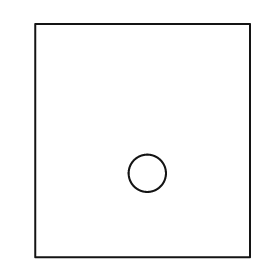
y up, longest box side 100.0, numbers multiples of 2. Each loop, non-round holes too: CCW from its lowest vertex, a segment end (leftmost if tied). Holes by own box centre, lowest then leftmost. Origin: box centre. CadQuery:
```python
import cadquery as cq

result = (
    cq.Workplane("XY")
    .moveTo(-46.0, -50.0)
    .lineTo(46.0, -50.0)
    .lineTo(46.0, 50.0)
    .lineTo(-46.0, 50.0)
    .close()
    .moveTo(2.0, -14.0)
    .circle(8.0)
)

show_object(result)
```